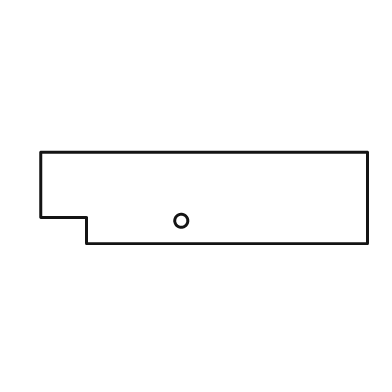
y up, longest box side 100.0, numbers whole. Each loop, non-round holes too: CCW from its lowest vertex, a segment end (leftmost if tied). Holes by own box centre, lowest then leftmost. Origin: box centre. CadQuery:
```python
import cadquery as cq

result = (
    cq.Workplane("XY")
    .moveTo(-36.0, -14.0)
    .lineTo(50.0, -14.0)
    .lineTo(50.0, 14.0)
    .lineTo(-50.0, 14.0)
    .lineTo(-50.0, -6.0)
    .lineTo(-36.0, -6.0)
    .close()
    .moveTo(-7.0, -7.0)
    .circle(2.0)
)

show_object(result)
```